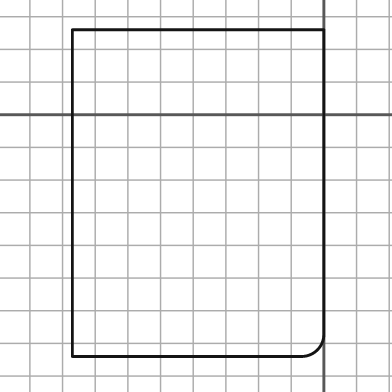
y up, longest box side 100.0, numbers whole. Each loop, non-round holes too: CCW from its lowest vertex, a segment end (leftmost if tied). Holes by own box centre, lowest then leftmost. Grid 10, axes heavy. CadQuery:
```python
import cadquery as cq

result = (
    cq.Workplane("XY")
    .moveTo(-77.0, -74.0)
    .lineTo(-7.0, -74.0)
    .threePointArc((-2.0, -72.0), (0.0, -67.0))
    .lineTo(0.0, 26.0)
    .lineTo(-77.0, 26.0)
    .close()
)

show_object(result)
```